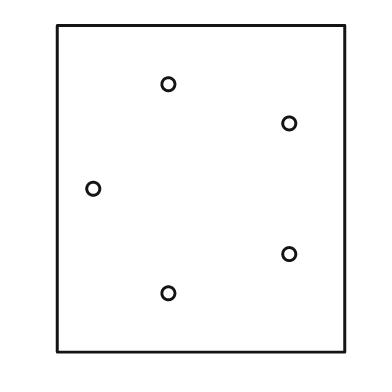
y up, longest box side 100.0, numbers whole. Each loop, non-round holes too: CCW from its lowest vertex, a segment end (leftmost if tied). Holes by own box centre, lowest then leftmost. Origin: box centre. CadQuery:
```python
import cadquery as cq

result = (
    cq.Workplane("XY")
    .moveTo(-44.0, -50.0)
    .lineTo(44.0, -50.0)
    .lineTo(44.0, 50.0)
    .lineTo(-44.0, 50.0)
    .close()
    .moveTo(-10.0, -32.0)
    .circle(2.0)
    .moveTo(27.0, -20.0)
    .circle(2.0)
    .moveTo(-33.0, 0.0)
    .circle(2.0)
    .moveTo(27.0, 20.0)
    .circle(2.0)
    .moveTo(-10.0, 32.0)
    .circle(2.0)
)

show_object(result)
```